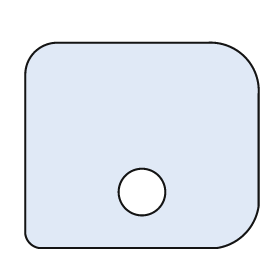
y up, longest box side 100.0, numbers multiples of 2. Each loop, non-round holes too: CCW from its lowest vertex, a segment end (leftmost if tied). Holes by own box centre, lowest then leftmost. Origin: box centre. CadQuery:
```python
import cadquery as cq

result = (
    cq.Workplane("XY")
    .moveTo(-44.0, -44.0)
    .lineTo(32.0, -44.0)
    .threePointArc((44.0, -38.0), (50.0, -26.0))
    .lineTo(50.0, 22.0)
    .threePointArc((44.0, 38.0), (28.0, 44.0))
    .lineTo(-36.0, 44.0)
    .threePointArc((-46.0, 40.0), (-50.0, 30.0))
    .lineTo(-50.0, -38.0)
    .threePointArc((-48.0, -42.0), (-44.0, -44.0))
    .close()
    .moveTo(0.0, -20.0)
    .circle(10.0)
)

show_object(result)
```